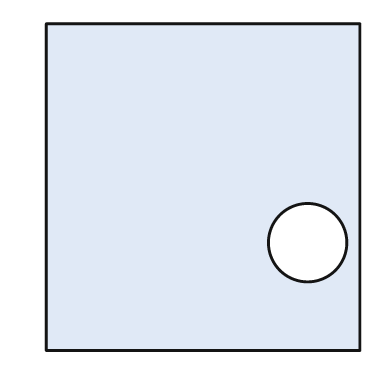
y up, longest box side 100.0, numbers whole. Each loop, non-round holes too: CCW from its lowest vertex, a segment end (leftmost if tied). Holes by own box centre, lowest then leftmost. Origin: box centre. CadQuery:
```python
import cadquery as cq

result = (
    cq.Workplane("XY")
    .moveTo(-48.0, -50.0)
    .lineTo(48.0, -50.0)
    .lineTo(48.0, 50.0)
    .lineTo(-48.0, 50.0)
    .close()
    .moveTo(32.0, -17.0)
    .circle(12.0)
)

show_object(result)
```